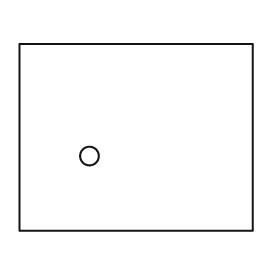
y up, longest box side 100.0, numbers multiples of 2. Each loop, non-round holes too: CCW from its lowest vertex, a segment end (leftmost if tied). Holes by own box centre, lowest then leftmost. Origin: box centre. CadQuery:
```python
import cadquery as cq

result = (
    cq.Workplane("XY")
    .moveTo(-50.0, -40.0)
    .lineTo(50.0, -40.0)
    .lineTo(50.0, 40.0)
    .lineTo(-50.0, 40.0)
    .close()
    .moveTo(-20.0, -8.0)
    .circle(4.0)
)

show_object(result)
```